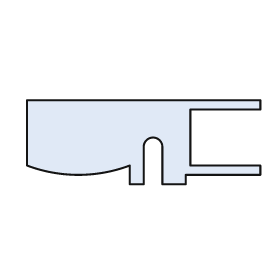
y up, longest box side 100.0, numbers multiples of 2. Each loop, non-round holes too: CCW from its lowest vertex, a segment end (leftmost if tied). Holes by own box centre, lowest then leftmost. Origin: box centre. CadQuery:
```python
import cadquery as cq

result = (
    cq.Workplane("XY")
    .moveTo(-6.0, -18.0)
    .lineTo(0.0, -18.0)
    .lineTo(0.0, -2.0)
    .threePointArc((4.0, 2.0), (8.0, -2.0))
    .lineTo(8.0, -18.0)
    .lineTo(18.0, -18.0)
    .lineTo(18.0, -14.0)
    .lineTo(50.0, -14.0)
    .lineTo(50.0, -10.0)
    .lineTo(20.0, -10.0)
    .lineTo(20.0, 14.0)
    .lineTo(50.0, 14.0)
    .lineTo(50.0, 18.0)
    .lineTo(-50.0, 18.0)
    .lineTo(-50.0, -10.0)
    .threePointArc((-28.0, -14.0), (-6.0, -10.0))
    .close()
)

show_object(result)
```